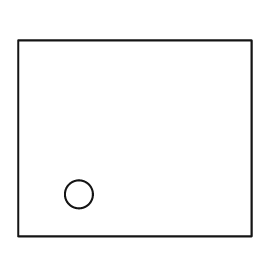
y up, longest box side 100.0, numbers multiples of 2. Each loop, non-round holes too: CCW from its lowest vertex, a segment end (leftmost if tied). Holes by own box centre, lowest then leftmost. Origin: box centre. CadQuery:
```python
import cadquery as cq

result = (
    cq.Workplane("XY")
    .moveTo(-50.0, -42.0)
    .lineTo(50.0, -42.0)
    .lineTo(50.0, 42.0)
    .lineTo(-50.0, 42.0)
    .close()
    .moveTo(-24.0, -24.0)
    .circle(6.0)
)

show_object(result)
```